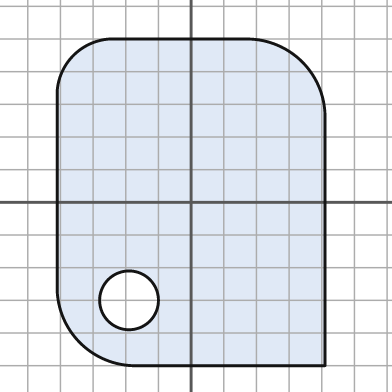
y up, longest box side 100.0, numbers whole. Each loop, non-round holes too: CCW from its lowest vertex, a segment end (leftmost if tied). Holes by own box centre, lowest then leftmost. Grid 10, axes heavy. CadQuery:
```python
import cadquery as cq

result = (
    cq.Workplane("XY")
    .moveTo(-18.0, -50.0)
    .lineTo(41.0, -50.0)
    .lineTo(41.0, 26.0)
    .threePointArc((34.0, 43.0), (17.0, 50.0))
    .lineTo(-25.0, 50.0)
    .threePointArc((-36.0, 45.0), (-41.0, 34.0))
    .lineTo(-41.0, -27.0)
    .threePointArc((-34.0, -43.0), (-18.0, -50.0))
    .close()
    .moveTo(-19.0, -30.0)
    .circle(9.0)
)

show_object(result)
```